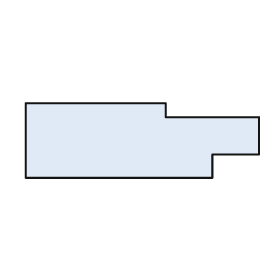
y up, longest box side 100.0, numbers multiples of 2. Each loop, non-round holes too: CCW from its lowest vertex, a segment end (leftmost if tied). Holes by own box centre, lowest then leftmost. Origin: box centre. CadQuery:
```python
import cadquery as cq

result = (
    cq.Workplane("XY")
    .moveTo(-50.0, -16.0)
    .lineTo(30.0, -16.0)
    .lineTo(30.0, -6.0)
    .lineTo(50.0, -6.0)
    .lineTo(50.0, 10.0)
    .lineTo(10.0, 10.0)
    .lineTo(10.0, 16.0)
    .lineTo(-50.0, 16.0)
    .close()
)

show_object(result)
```